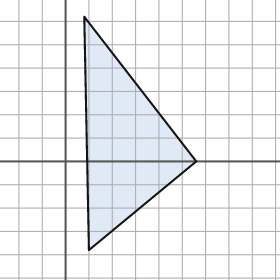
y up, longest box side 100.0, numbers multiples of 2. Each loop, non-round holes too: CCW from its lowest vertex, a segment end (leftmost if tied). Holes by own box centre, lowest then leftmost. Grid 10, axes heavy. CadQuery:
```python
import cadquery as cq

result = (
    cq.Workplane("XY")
    .moveTo(10.0, -38.0)
    .lineTo(56.0, 0.0)
    .lineTo(8.0, 62.0)
    .close()
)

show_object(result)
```